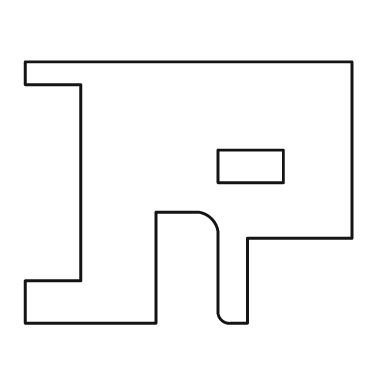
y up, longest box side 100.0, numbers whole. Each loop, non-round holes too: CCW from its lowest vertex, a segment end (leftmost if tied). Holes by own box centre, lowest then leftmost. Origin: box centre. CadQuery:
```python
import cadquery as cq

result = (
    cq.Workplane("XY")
    .moveTo(-50.0, -40.0)
    .lineTo(-10.0, -40.0)
    .lineTo(-10.0, -6.0)
    .lineTo(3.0, -6.0)
    .threePointArc((7.0, -8.0), (9.0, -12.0))
    .lineTo(9.0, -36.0)
    .threePointArc((10.0, -39.0), (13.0, -40.0))
    .lineTo(18.0, -40.0)
    .lineTo(18.0, -14.0)
    .lineTo(50.0, -14.0)
    .lineTo(50.0, 40.0)
    .lineTo(-50.0, 40.0)
    .lineTo(-50.0, 33.0)
    .lineTo(-33.0, 33.0)
    .lineTo(-33.0, -27.0)
    .lineTo(-50.0, -27.0)
    .close()
    .moveTo(9.0, 3.0)
    .lineTo(29.0, 3.0)
    .lineTo(29.0, 13.0)
    .lineTo(9.0, 13.0)
    .close()
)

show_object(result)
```